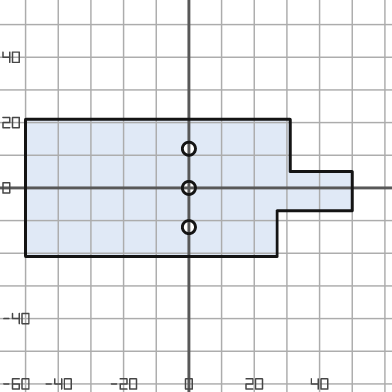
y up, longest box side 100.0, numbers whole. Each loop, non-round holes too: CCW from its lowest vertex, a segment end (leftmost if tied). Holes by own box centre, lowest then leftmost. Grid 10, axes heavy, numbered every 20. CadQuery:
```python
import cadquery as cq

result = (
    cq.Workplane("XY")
    .moveTo(-50.0, -21.0)
    .lineTo(27.0, -21.0)
    .lineTo(27.0, -7.0)
    .lineTo(50.0, -7.0)
    .lineTo(50.0, 5.0)
    .lineTo(31.0, 5.0)
    .lineTo(31.0, 21.0)
    .lineTo(-50.0, 21.0)
    .close()
    .moveTo(0.0, -12.0)
    .circle(2.0)
    .moveTo(0.0, 0.0)
    .circle(2.0)
    .moveTo(0.0, 12.0)
    .circle(2.0)
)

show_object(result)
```